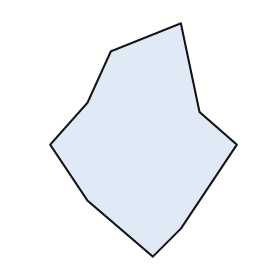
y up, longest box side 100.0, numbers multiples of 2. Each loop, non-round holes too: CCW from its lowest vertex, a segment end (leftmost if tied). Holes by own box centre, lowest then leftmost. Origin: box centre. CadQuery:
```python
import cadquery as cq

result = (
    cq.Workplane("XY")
    .moveTo(4.0, -50.0)
    .lineTo(16.0, -38.0)
    .lineTo(40.0, -2.0)
    .lineTo(24.0, 12.0)
    .lineTo(16.0, 50.0)
    .lineTo(-14.0, 38.0)
    .lineTo(-24.0, 16.0)
    .lineTo(-40.0, -2.0)
    .lineTo(-24.0, -26.0)
    .close()
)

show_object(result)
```